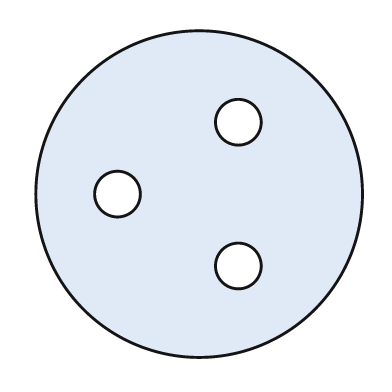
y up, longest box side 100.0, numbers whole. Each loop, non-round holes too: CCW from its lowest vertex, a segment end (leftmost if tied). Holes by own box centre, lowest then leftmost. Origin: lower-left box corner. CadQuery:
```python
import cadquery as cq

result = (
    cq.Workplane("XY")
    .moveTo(50.0, 50.0)
    .circle(50.0)
    .moveTo(62.0, 28.0)
    .circle(7.0)
    .moveTo(25.0, 50.0)
    .circle(7.0)
    .moveTo(62.0, 72.0)
    .circle(7.0)
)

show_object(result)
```